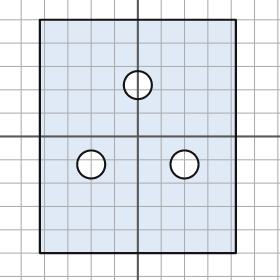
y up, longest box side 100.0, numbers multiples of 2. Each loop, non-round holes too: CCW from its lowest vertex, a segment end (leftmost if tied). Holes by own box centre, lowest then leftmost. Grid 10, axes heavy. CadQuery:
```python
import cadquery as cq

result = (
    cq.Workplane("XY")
    .moveTo(-42.0, -50.0)
    .lineTo(42.0, -50.0)
    .lineTo(42.0, 50.0)
    .lineTo(-42.0, 50.0)
    .close()
    .moveTo(-20.0, -12.0)
    .circle(6.0)
    .moveTo(20.0, -12.0)
    .circle(6.0)
    .moveTo(0.0, 22.0)
    .circle(6.0)
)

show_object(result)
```